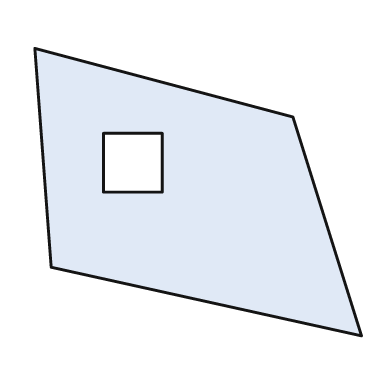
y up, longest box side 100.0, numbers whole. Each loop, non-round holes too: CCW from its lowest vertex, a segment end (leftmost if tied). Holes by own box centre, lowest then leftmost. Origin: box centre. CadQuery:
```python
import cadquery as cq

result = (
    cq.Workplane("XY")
    .moveTo(50.0, -44.0)
    .lineTo(29.0, 23.0)
    .lineTo(-50.0, 44.0)
    .lineTo(-45.0, -23.0)
    .close()
    .moveTo(-29.0, 0.0)
    .lineTo(-11.0, 0.0)
    .lineTo(-11.0, 18.0)
    .lineTo(-29.0, 18.0)
    .close()
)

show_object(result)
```